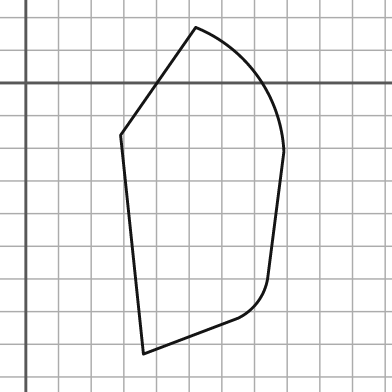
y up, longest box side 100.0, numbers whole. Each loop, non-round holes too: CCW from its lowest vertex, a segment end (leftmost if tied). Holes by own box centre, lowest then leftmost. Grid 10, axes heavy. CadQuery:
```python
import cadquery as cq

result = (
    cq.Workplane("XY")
    .moveTo(36.0, -83.0)
    .lineTo(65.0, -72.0)
    .threePointArc((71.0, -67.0), (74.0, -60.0))
    .lineTo(79.0, -21.0)
    .threePointArc((71.0, 2.0), (52.0, 17.0))
    .lineTo(29.0, -16.0)
    .close()
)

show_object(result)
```